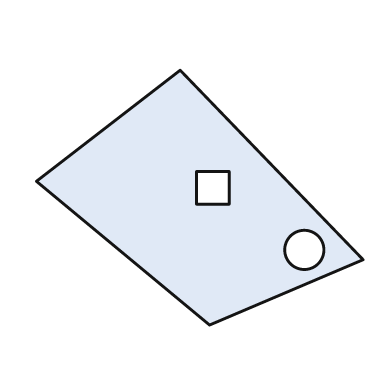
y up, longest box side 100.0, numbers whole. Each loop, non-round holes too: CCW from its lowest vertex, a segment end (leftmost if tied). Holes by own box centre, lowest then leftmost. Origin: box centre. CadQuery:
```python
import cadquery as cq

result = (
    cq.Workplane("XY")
    .moveTo(3.0, -39.0)
    .lineTo(50.0, -19.0)
    .lineTo(-6.0, 39.0)
    .lineTo(-50.0, 5.0)
    .close()
    .moveTo(32.0, -16.0)
    .circle(6.0)
    .moveTo(-1.0, -2.0)
    .lineTo(9.0, -2.0)
    .lineTo(9.0, 8.0)
    .lineTo(-1.0, 8.0)
    .close()
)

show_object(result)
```